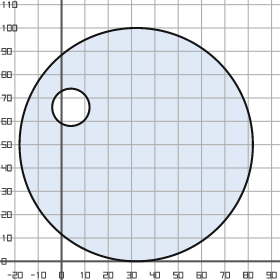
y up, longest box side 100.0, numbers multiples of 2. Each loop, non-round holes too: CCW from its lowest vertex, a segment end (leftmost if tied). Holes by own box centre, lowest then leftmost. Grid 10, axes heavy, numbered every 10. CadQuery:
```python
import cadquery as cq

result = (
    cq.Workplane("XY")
    .moveTo(32.0, 50.0)
    .circle(50.0)
    .moveTo(4.0, 66.0)
    .circle(8.0)
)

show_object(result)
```